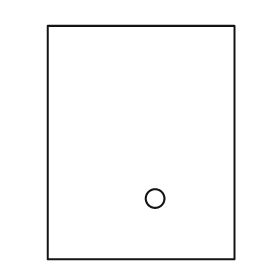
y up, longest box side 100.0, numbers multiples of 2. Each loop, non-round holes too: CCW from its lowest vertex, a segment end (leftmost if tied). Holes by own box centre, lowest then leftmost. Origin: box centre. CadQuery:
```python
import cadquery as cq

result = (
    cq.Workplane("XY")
    .moveTo(-40.0, -50.0)
    .lineTo(40.0, -50.0)
    .lineTo(40.0, 50.0)
    .lineTo(-40.0, 50.0)
    .close()
    .moveTo(6.0, -24.0)
    .circle(4.0)
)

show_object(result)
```